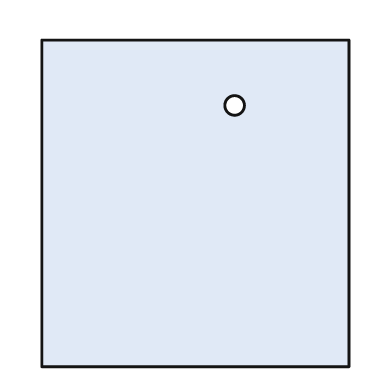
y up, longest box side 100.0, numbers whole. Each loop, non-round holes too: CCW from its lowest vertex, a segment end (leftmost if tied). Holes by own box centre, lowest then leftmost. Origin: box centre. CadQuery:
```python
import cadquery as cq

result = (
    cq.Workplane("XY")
    .moveTo(-47.0, -50.0)
    .lineTo(47.0, -50.0)
    .lineTo(47.0, 50.0)
    .lineTo(-47.0, 50.0)
    .close()
    .moveTo(12.0, 30.0)
    .circle(3.0)
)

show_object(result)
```